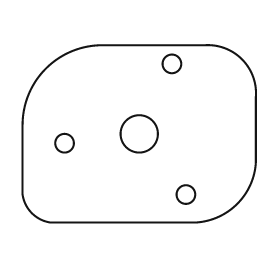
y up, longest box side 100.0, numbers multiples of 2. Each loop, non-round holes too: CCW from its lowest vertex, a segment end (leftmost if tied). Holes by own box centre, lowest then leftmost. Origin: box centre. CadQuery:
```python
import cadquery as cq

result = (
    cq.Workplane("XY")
    .moveTo(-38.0, -38.0)
    .lineTo(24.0, -38.0)
    .threePointArc((42.0, -30.0), (50.0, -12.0))
    .lineTo(50.0, 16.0)
    .threePointArc((44.0, 32.0), (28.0, 38.0))
    .lineTo(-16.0, 38.0)
    .threePointArc((-40.0, 28.0), (-50.0, 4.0))
    .lineTo(-50.0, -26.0)
    .threePointArc((-46.0, -34.0), (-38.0, -38.0))
    .close()
    .moveTo(20.0, -26.0)
    .circle(4.0)
    .moveTo(-32.0, -4.0)
    .circle(4.0)
    .moveTo(0.0, 0.0)
    .circle(8.0)
    .moveTo(14.0, 30.0)
    .circle(4.0)
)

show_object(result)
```